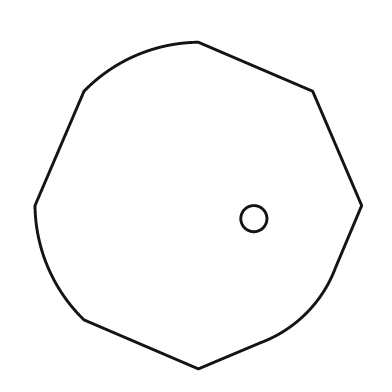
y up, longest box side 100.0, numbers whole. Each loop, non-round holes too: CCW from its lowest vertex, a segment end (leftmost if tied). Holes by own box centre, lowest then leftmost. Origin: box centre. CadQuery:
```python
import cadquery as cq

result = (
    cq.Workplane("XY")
    .moveTo(0.0, -50.0)
    .lineTo(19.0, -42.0)
    .threePointArc((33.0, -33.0), (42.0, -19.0))
    .lineTo(50.0, 0.0)
    .lineTo(35.0, 35.0)
    .lineTo(0.0, 50.0)
    .threePointArc((-19.0, 46.0), (-35.0, 35.0))
    .lineTo(-50.0, 0.0)
    .threePointArc((-46.0, -19.0), (-35.0, -35.0))
    .close()
    .moveTo(17.0, -4.0)
    .circle(4.0)
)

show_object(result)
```